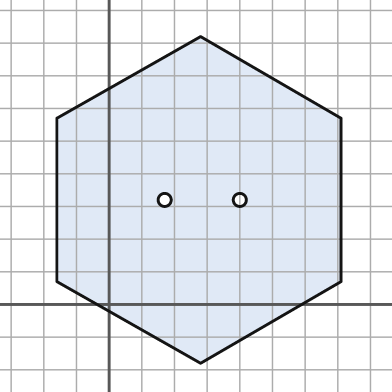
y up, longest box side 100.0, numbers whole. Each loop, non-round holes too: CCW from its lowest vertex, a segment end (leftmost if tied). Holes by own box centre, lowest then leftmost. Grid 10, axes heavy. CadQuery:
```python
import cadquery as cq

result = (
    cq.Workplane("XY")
    .moveTo(28.0, -18.0)
    .lineTo(71.0, 7.0)
    .lineTo(71.0, 57.0)
    .lineTo(28.0, 82.0)
    .lineTo(-16.0, 57.0)
    .lineTo(-16.0, 7.0)
    .close()
    .moveTo(17.0, 32.0)
    .circle(2.0)
    .moveTo(40.0, 32.0)
    .circle(2.0)
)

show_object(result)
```